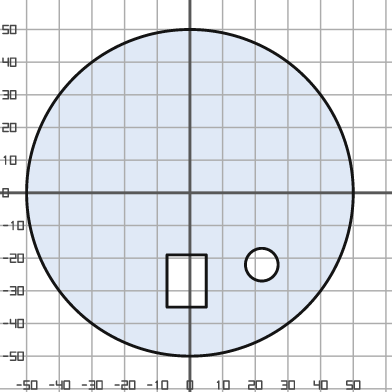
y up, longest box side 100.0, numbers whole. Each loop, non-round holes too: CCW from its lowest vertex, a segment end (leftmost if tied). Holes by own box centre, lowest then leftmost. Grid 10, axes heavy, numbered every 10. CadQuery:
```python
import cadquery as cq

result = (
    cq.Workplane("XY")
    .moveTo(0.0, 0.0)
    .circle(50.0)
    .moveTo(-7.0, -35.0)
    .lineTo(5.0, -35.0)
    .lineTo(5.0, -19.0)
    .lineTo(-7.0, -19.0)
    .close()
    .moveTo(22.0, -22.0)
    .circle(5.0)
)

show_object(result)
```